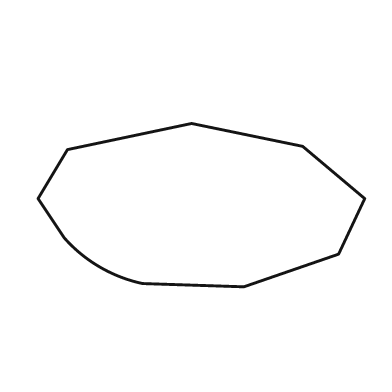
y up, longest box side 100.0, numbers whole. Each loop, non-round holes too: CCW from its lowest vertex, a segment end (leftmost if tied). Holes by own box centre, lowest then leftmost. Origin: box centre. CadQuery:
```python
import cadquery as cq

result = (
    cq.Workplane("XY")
    .moveTo(13.0, -25.0)
    .lineTo(42.0, -15.0)
    .lineTo(50.0, 2.0)
    .lineTo(31.0, 18.0)
    .lineTo(-3.0, 25.0)
    .lineTo(-41.0, 17.0)
    .lineTo(-50.0, 2.0)
    .lineTo(-42.0, -10.0)
    .threePointArc((-31.0, -19.0), (-18.0, -24.0))
    .close()
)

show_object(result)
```